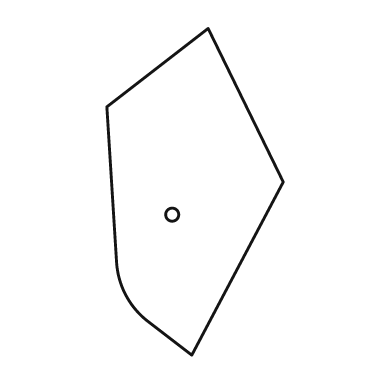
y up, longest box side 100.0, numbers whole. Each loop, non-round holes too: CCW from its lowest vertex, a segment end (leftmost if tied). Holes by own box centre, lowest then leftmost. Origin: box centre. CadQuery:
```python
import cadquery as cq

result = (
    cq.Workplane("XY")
    .moveTo(-1.0, -50.0)
    .lineTo(27.0, 3.0)
    .lineTo(4.0, 50.0)
    .lineTo(-27.0, 26.0)
    .lineTo(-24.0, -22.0)
    .threePointArc((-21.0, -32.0), (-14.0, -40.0))
    .close()
    .moveTo(-7.0, -7.0)
    .circle(2.0)
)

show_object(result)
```